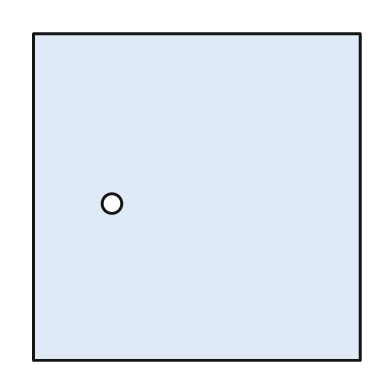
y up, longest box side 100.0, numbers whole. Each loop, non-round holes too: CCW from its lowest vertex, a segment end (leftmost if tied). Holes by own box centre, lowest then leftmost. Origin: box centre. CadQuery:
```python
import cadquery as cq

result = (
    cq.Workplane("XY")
    .moveTo(-50.0, -50.0)
    .lineTo(50.0, -50.0)
    .lineTo(50.0, 50.0)
    .lineTo(-50.0, 50.0)
    .close()
    .moveTo(-26.0, -2.0)
    .circle(3.0)
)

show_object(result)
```